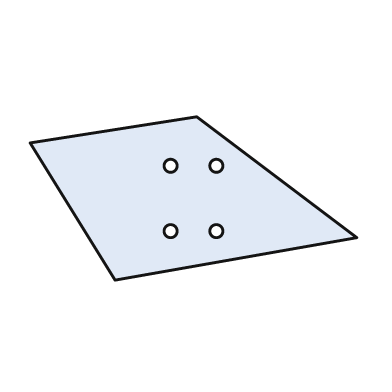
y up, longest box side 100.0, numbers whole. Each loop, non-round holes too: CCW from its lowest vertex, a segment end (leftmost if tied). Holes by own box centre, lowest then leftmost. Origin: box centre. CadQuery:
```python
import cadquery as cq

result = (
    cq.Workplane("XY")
    .moveTo(-24.0, -25.0)
    .lineTo(50.0, -12.0)
    .lineTo(1.0, 25.0)
    .lineTo(-50.0, 17.0)
    .close()
    .moveTo(-7.0, -10.0)
    .circle(2.0)
    .moveTo(7.0, -10.0)
    .circle(2.0)
    .moveTo(-7.0, 10.0)
    .circle(2.0)
    .moveTo(7.0, 10.0)
    .circle(2.0)
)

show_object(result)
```